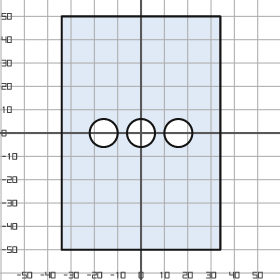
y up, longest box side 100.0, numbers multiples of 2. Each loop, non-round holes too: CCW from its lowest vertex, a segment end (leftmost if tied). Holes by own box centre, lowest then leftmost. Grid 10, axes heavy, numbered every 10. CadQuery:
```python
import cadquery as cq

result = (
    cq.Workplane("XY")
    .moveTo(-34.0, -50.0)
    .lineTo(34.0, -50.0)
    .lineTo(34.0, 50.0)
    .lineTo(-34.0, 50.0)
    .close()
    .moveTo(-16.0, 0.0)
    .circle(6.0)
    .moveTo(0.0, 0.0)
    .circle(6.0)
    .moveTo(16.0, 0.0)
    .circle(6.0)
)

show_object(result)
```